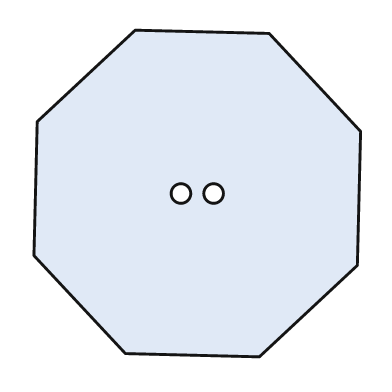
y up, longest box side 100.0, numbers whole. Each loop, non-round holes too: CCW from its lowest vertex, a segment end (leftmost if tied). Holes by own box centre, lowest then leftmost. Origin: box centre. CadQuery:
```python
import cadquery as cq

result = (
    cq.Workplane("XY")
    .moveTo(19.0, -50.0)
    .lineTo(49.0, -22.0)
    .lineTo(50.0, 19.0)
    .lineTo(22.0, 49.0)
    .lineTo(-19.0, 50.0)
    .lineTo(-49.0, 22.0)
    .lineTo(-50.0, -19.0)
    .lineTo(-22.0, -49.0)
    .close()
    .moveTo(-5.0, 0.0)
    .circle(3.0)
    .moveTo(5.0, 0.0)
    .circle(3.0)
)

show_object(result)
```